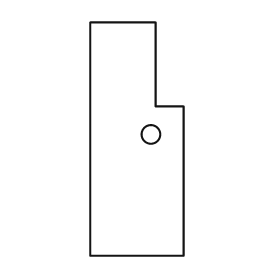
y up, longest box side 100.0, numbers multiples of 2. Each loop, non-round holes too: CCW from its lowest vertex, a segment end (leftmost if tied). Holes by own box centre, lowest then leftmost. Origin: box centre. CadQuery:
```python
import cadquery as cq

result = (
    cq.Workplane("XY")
    .moveTo(-20.0, -50.0)
    .lineTo(20.0, -50.0)
    .lineTo(20.0, 14.0)
    .lineTo(8.0, 14.0)
    .lineTo(8.0, 50.0)
    .lineTo(-20.0, 50.0)
    .close()
    .moveTo(6.0, 2.0)
    .circle(4.0)
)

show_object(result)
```